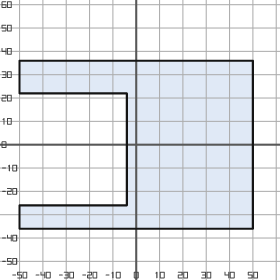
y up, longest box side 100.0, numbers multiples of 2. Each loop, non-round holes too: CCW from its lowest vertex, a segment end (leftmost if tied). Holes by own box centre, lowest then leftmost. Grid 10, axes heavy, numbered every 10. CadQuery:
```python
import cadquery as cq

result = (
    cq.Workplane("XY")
    .moveTo(-50.0, -36.0)
    .lineTo(50.0, -36.0)
    .lineTo(50.0, 36.0)
    .lineTo(-50.0, 36.0)
    .lineTo(-50.0, 22.0)
    .lineTo(-4.0, 22.0)
    .lineTo(-4.0, -26.0)
    .lineTo(-50.0, -26.0)
    .close()
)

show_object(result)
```